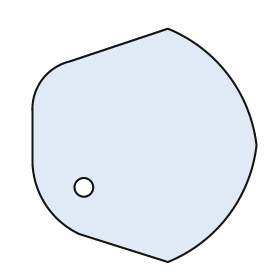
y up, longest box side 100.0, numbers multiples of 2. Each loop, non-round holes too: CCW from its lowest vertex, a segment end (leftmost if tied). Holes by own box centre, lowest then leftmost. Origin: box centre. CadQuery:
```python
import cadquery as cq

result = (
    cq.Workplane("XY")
    .moveTo(10.0, -50.0)
    .threePointArc((36.0, -30.0), (48.0, 0.0))
    .threePointArc((36.0, 30.0), (10.0, 50.0))
    .lineTo(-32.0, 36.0)
    .threePointArc((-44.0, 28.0), (-48.0, 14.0))
    .lineTo(-48.0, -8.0)
    .threePointArc((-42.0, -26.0), (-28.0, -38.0))
    .close()
    .moveTo(-26.0, -18.0)
    .circle(4.0)
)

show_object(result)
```